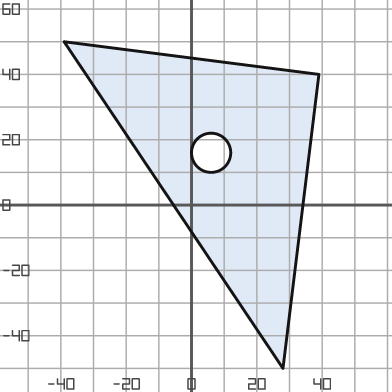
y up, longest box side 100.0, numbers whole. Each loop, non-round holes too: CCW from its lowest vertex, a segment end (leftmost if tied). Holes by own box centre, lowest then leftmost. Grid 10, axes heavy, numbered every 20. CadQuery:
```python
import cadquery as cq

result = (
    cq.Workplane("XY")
    .moveTo(28.0, -50.0)
    .lineTo(39.0, 40.0)
    .lineTo(-39.0, 50.0)
    .close()
    .moveTo(6.0, 16.0)
    .circle(6.0)
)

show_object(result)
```